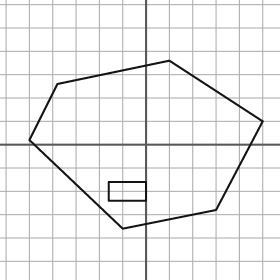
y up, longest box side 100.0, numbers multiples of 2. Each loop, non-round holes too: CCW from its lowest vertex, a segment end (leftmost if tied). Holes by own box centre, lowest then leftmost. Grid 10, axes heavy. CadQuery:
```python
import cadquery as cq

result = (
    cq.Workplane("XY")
    .moveTo(-10.0, -36.0)
    .lineTo(30.0, -28.0)
    .lineTo(50.0, 10.0)
    .lineTo(10.0, 36.0)
    .lineTo(-38.0, 26.0)
    .lineTo(-50.0, 2.0)
    .close()
    .moveTo(-16.0, -24.0)
    .lineTo(0.0, -24.0)
    .lineTo(0.0, -16.0)
    .lineTo(-16.0, -16.0)
    .close()
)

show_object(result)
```